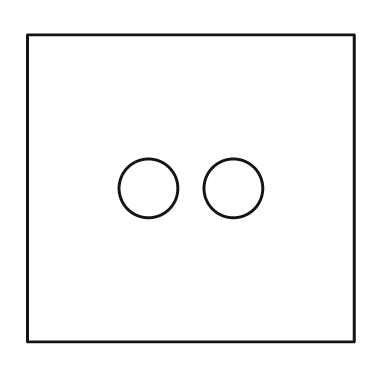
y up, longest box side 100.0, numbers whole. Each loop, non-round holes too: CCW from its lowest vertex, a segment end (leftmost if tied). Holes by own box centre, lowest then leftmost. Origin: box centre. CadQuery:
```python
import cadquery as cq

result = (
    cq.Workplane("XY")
    .moveTo(-50.0, -47.0)
    .lineTo(50.0, -47.0)
    .lineTo(50.0, 47.0)
    .lineTo(-50.0, 47.0)
    .close()
    .moveTo(-13.0, 0.0)
    .circle(9.0)
    .moveTo(13.0, 0.0)
    .circle(9.0)
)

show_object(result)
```